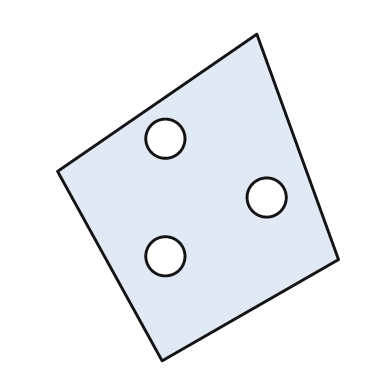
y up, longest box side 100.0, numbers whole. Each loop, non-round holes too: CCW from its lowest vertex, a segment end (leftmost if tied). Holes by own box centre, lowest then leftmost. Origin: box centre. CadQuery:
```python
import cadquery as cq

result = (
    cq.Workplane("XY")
    .moveTo(-11.0, -50.0)
    .lineTo(43.0, -19.0)
    .lineTo(18.0, 50.0)
    .lineTo(-43.0, 8.0)
    .close()
    .moveTo(-10.0, -18.0)
    .circle(6.0)
    .moveTo(21.0, 0.0)
    .circle(6.0)
    .moveTo(-10.0, 18.0)
    .circle(6.0)
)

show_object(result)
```